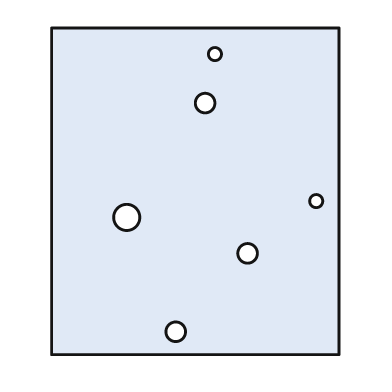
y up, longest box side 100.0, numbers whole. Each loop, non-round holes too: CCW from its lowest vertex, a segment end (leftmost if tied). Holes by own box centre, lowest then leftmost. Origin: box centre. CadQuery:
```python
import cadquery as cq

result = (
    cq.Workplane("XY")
    .moveTo(-44.0, -50.0)
    .lineTo(44.0, -50.0)
    .lineTo(44.0, 50.0)
    .lineTo(-44.0, 50.0)
    .close()
    .moveTo(-6.0, -43.0)
    .circle(3.0)
    .moveTo(16.0, -19.0)
    .circle(3.0)
    .moveTo(-21.0, -8.0)
    .circle(4.0)
    .moveTo(37.0, -3.0)
    .circle(2.0)
    .moveTo(3.0, 27.0)
    .circle(3.0)
    .moveTo(6.0, 42.0)
    .circle(2.0)
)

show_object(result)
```